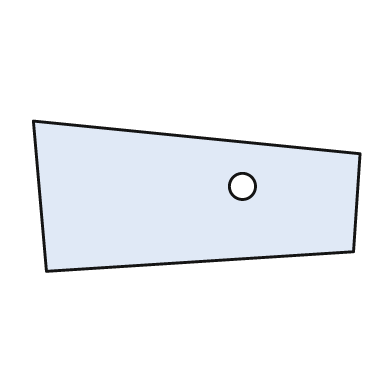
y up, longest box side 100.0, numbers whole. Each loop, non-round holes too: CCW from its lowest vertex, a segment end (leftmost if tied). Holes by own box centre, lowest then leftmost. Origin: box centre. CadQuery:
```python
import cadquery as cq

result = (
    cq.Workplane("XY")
    .moveTo(-46.0, -23.0)
    .lineTo(48.0, -17.0)
    .lineTo(50.0, 13.0)
    .lineTo(-50.0, 23.0)
    .close()
    .moveTo(14.0, 3.0)
    .circle(4.0)
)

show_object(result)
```